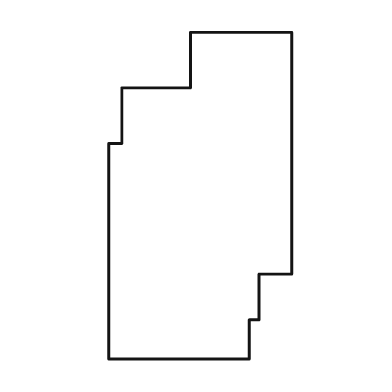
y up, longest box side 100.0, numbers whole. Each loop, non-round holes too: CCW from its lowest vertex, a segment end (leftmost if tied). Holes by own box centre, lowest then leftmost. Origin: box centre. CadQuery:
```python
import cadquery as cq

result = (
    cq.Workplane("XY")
    .moveTo(-28.0, -50.0)
    .lineTo(15.0, -50.0)
    .lineTo(15.0, -38.0)
    .lineTo(18.0, -38.0)
    .lineTo(18.0, -24.0)
    .lineTo(28.0, -24.0)
    .lineTo(28.0, 50.0)
    .lineTo(-3.0, 50.0)
    .lineTo(-3.0, 33.0)
    .lineTo(-24.0, 33.0)
    .lineTo(-24.0, 16.0)
    .lineTo(-28.0, 16.0)
    .close()
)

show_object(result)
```